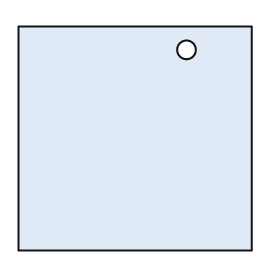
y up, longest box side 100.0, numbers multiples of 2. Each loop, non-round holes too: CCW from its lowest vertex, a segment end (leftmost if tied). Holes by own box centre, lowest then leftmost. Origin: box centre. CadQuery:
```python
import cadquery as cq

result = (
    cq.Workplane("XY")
    .moveTo(-50.0, -48.0)
    .lineTo(50.0, -48.0)
    .lineTo(50.0, 48.0)
    .lineTo(-50.0, 48.0)
    .close()
    .moveTo(22.0, 38.0)
    .circle(4.0)
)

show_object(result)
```